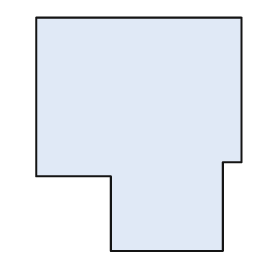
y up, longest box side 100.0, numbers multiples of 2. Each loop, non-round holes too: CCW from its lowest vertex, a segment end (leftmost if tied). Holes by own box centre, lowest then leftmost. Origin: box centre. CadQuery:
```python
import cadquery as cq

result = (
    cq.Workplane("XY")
    .moveTo(-12.0, -50.0)
    .lineTo(36.0, -50.0)
    .lineTo(36.0, -12.0)
    .lineTo(44.0, -12.0)
    .lineTo(44.0, 50.0)
    .lineTo(-44.0, 50.0)
    .lineTo(-44.0, -18.0)
    .lineTo(-12.0, -18.0)
    .close()
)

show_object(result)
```